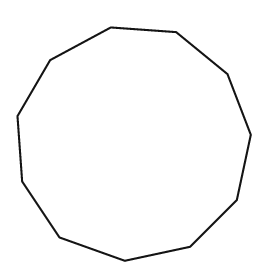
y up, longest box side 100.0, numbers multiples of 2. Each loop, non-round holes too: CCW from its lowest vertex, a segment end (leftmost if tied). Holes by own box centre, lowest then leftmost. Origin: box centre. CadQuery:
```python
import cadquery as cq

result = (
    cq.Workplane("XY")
    .moveTo(-4.0, -50.0)
    .lineTo(24.0, -44.0)
    .lineTo(44.0, -24.0)
    .lineTo(50.0, 4.0)
    .lineTo(40.0, 30.0)
    .lineTo(18.0, 48.0)
    .lineTo(-10.0, 50.0)
    .lineTo(-36.0, 36.0)
    .lineTo(-50.0, 12.0)
    .lineTo(-48.0, -16.0)
    .lineTo(-32.0, -40.0)
    .close()
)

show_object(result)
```